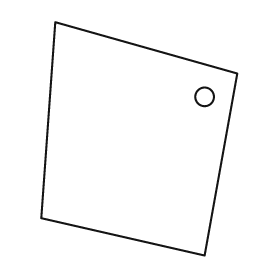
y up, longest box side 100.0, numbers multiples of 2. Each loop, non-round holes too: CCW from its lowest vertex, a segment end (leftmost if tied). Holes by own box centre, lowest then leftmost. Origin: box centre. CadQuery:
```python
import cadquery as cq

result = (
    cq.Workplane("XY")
    .moveTo(28.0, -50.0)
    .lineTo(42.0, 28.0)
    .lineTo(-36.0, 50.0)
    .lineTo(-42.0, -34.0)
    .close()
    .moveTo(28.0, 18.0)
    .circle(4.0)
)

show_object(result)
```